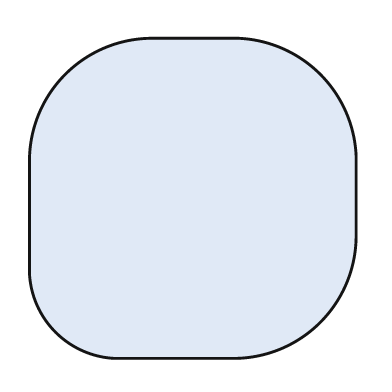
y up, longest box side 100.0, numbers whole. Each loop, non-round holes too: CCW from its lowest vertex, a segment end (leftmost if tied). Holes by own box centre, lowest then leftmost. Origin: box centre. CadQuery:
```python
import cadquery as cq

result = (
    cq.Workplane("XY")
    .moveTo(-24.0, -49.0)
    .lineTo(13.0, -49.0)
    .threePointArc((39.0, -38.0), (50.0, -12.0))
    .lineTo(50.0, 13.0)
    .threePointArc((39.0, 38.0), (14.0, 49.0))
    .lineTo(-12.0, 49.0)
    .threePointArc((-39.0, 38.0), (-50.0, 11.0))
    .lineTo(-50.0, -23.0)
    .threePointArc((-42.0, -41.0), (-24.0, -49.0))
    .close()
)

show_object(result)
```